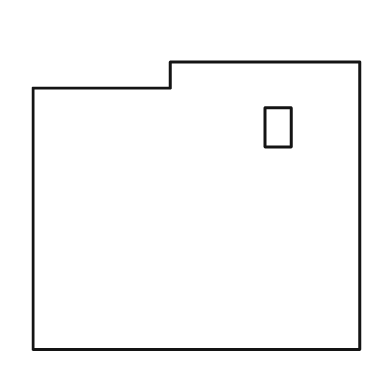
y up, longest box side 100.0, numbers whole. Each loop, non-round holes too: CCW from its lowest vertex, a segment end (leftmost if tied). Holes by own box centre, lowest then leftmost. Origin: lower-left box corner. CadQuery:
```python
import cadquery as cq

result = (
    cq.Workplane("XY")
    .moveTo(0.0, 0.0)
    .lineTo(100.0, 0.0)
    .lineTo(100.0, 88.0)
    .lineTo(42.0, 88.0)
    .lineTo(42.0, 80.0)
    .lineTo(0.0, 80.0)
    .close()
    .moveTo(71.0, 62.0)
    .lineTo(79.0, 62.0)
    .lineTo(79.0, 74.0)
    .lineTo(71.0, 74.0)
    .close()
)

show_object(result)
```